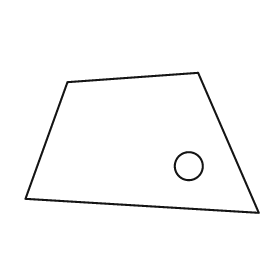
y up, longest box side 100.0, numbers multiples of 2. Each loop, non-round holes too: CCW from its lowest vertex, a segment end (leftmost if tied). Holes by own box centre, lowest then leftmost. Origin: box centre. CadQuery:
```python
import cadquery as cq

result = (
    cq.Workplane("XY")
    .moveTo(50.0, -30.0)
    .lineTo(24.0, 30.0)
    .lineTo(-32.0, 26.0)
    .lineTo(-50.0, -24.0)
    .close()
    .moveTo(20.0, -10.0)
    .circle(6.0)
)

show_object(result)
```